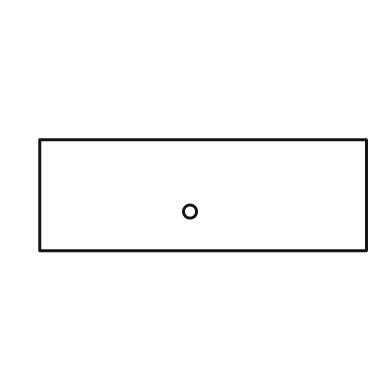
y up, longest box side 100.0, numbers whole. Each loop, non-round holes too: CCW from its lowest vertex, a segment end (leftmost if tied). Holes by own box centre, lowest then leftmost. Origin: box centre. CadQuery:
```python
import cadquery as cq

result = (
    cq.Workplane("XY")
    .moveTo(-50.0, -17.0)
    .lineTo(50.0, -17.0)
    .lineTo(50.0, 17.0)
    .lineTo(-50.0, 17.0)
    .close()
    .moveTo(-4.0, -5.0)
    .circle(2.0)
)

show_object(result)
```